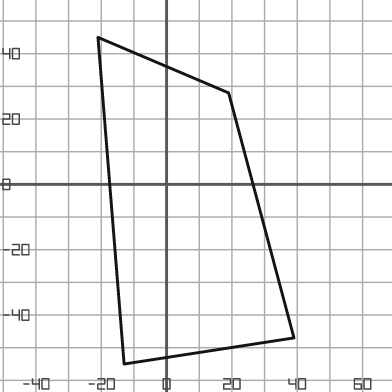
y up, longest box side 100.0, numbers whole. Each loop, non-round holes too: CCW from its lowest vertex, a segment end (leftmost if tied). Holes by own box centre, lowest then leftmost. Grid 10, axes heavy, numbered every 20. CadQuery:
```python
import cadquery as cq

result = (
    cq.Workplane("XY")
    .moveTo(-13.0, -55.0)
    .lineTo(39.0, -47.0)
    .lineTo(19.0, 28.0)
    .lineTo(-21.0, 45.0)
    .close()
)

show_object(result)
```